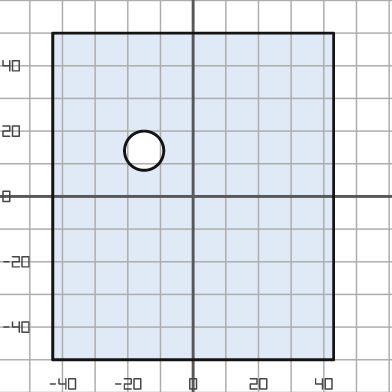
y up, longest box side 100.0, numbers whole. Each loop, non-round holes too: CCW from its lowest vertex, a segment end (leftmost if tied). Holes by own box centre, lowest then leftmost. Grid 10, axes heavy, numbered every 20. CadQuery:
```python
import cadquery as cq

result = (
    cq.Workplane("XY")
    .moveTo(-43.0, -50.0)
    .lineTo(43.0, -50.0)
    .lineTo(43.0, 50.0)
    .lineTo(-43.0, 50.0)
    .close()
    .moveTo(-15.0, 14.0)
    .circle(6.0)
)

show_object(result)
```